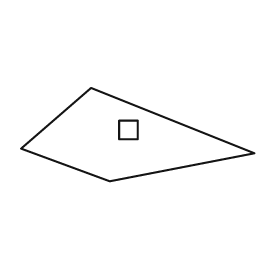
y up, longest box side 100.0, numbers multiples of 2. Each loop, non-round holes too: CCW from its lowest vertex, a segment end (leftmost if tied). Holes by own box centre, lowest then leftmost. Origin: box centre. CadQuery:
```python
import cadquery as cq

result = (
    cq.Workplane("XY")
    .moveTo(-12.0, -20.0)
    .lineTo(50.0, -8.0)
    .lineTo(-20.0, 20.0)
    .lineTo(-50.0, -6.0)
    .close()
    .moveTo(-8.0, -2.0)
    .lineTo(0.0, -2.0)
    .lineTo(0.0, 6.0)
    .lineTo(-8.0, 6.0)
    .close()
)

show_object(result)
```